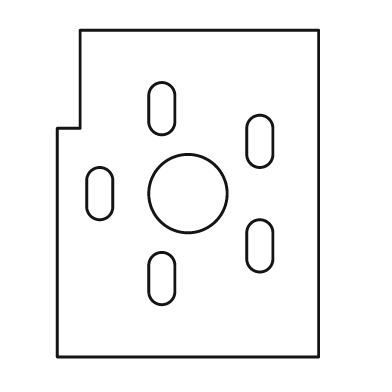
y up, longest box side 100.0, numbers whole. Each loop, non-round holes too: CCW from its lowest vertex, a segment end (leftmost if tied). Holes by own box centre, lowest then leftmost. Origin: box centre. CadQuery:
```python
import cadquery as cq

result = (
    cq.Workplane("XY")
    .moveTo(-40.0, -50.0)
    .lineTo(40.0, -50.0)
    .lineTo(40.0, 50.0)
    .lineTo(-33.0, 50.0)
    .lineTo(-33.0, 20.0)
    .lineTo(-40.0, 20.0)
    .close()
    .moveTo(-12.0, -30.0)
    .threePointArc((-8.0, -34.0), (-4.0, -30.0))
    .lineTo(-4.0, -22.0)
    .threePointArc((-8.0, -18.0), (-12.0, -22.0))
    .close()
    .moveTo(18.0, -20.0)
    .threePointArc((22.0, -24.0), (26.0, -20.0))
    .lineTo(26.0, -12.0)
    .threePointArc((22.0, -8.0), (18.0, -12.0))
    .close()
    .moveTo(-31.0, -4.0)
    .threePointArc((-27.0, -8.0), (-23.0, -4.0))
    .lineTo(-23.0, 4.0)
    .threePointArc((-27.0, 8.0), (-31.0, 4.0))
    .close()
    .moveTo(0.0, 0.0)
    .circle(12.0)
    .moveTo(18.0, 12.0)
    .threePointArc((22.0, 8.0), (26.0, 12.0))
    .lineTo(26.0, 20.0)
    .threePointArc((22.0, 24.0), (18.0, 20.0))
    .close()
    .moveTo(-12.0, 22.0)
    .threePointArc((-8.0, 18.0), (-4.0, 22.0))
    .lineTo(-4.0, 30.0)
    .threePointArc((-8.0, 34.0), (-12.0, 30.0))
    .close()
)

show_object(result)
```